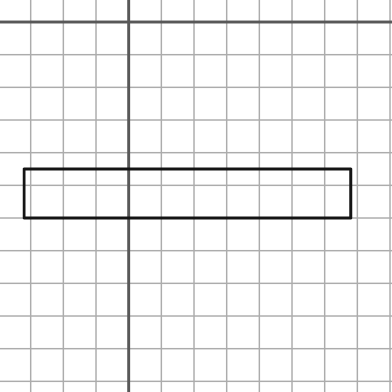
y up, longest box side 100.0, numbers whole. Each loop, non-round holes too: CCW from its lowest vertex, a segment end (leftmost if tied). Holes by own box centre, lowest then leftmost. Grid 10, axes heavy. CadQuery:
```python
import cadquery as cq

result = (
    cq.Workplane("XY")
    .moveTo(-32.0, -60.0)
    .lineTo(68.0, -60.0)
    .lineTo(68.0, -45.0)
    .lineTo(-32.0, -45.0)
    .close()
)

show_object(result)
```